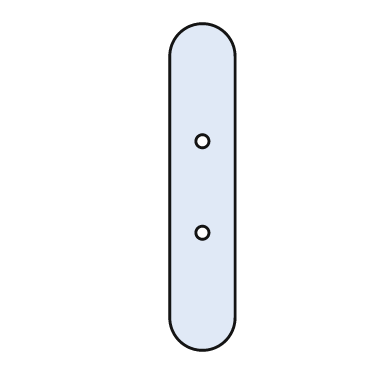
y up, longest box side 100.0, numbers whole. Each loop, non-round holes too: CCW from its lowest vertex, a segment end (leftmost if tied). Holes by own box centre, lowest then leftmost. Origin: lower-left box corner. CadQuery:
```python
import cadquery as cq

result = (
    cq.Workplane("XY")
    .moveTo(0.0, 10.0)
    .threePointArc((10.0, 0.0), (20.0, 10.0))
    .lineTo(20.0, 90.0)
    .threePointArc((10.0, 100.0), (0.0, 90.0))
    .close()
    .moveTo(10.0, 36.0)
    .circle(2.0)
    .moveTo(10.0, 64.0)
    .circle(2.0)
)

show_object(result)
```